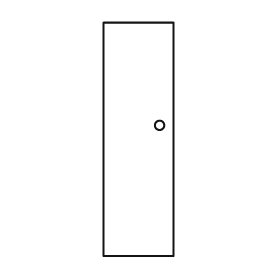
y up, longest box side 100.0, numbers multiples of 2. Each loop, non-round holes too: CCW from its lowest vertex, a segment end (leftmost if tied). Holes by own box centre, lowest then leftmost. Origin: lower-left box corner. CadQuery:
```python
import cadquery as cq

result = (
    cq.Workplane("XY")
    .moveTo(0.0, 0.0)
    .lineTo(30.0, 0.0)
    .lineTo(30.0, 100.0)
    .lineTo(0.0, 100.0)
    .close()
    .moveTo(24.0, 56.0)
    .circle(2.0)
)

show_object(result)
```